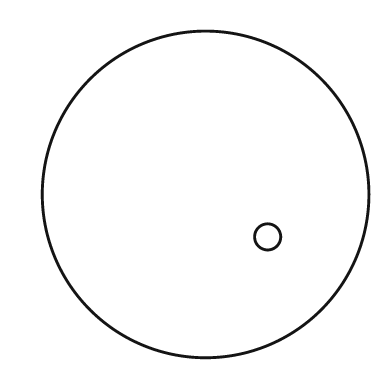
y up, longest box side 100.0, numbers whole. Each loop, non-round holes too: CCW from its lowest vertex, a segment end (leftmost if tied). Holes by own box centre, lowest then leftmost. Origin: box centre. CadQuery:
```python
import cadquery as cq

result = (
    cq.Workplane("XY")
    .moveTo(0.0, 0.0)
    .circle(50.0)
    .moveTo(19.0, -13.0)
    .circle(4.0)
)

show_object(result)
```